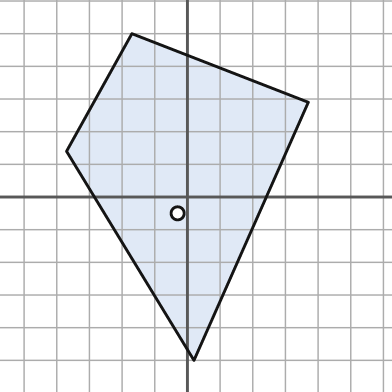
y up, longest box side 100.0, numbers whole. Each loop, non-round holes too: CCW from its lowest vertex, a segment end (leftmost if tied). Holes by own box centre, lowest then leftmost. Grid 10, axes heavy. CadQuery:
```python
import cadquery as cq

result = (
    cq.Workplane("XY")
    .moveTo(2.0, -50.0)
    .lineTo(37.0, 29.0)
    .lineTo(-17.0, 50.0)
    .lineTo(-37.0, 14.0)
    .close()
    .moveTo(-3.0, -5.0)
    .circle(2.0)
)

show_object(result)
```